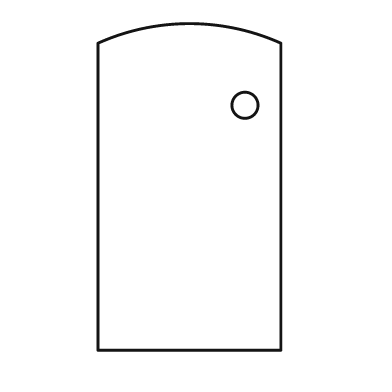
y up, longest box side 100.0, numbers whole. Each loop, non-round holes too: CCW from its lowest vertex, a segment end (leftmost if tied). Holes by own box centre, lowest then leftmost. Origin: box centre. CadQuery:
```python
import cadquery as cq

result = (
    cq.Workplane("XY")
    .moveTo(-28.0, -50.0)
    .lineTo(28.0, -50.0)
    .lineTo(28.0, 44.0)
    .threePointArc((0.0, 50.0), (-28.0, 44.0))
    .close()
    .moveTo(17.0, 25.0)
    .circle(4.0)
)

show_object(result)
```